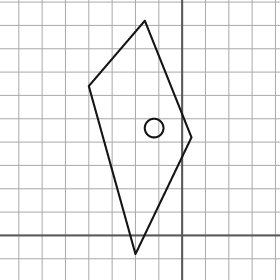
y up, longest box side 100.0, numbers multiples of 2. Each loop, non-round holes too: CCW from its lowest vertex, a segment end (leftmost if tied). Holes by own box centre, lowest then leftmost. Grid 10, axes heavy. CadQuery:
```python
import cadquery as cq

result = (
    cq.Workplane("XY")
    .moveTo(-20.0, -8.0)
    .lineTo(4.0, 42.0)
    .lineTo(-16.0, 92.0)
    .lineTo(-40.0, 64.0)
    .close()
    .moveTo(-12.0, 46.0)
    .circle(4.0)
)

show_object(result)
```